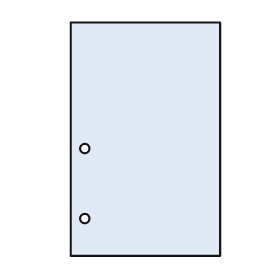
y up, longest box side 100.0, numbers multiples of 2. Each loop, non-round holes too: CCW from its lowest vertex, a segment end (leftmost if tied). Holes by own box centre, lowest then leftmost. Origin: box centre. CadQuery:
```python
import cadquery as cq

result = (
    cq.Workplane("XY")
    .moveTo(-32.0, -50.0)
    .lineTo(32.0, -50.0)
    .lineTo(32.0, 50.0)
    .lineTo(-32.0, 50.0)
    .close()
    .moveTo(-26.0, -34.0)
    .circle(2.0)
    .moveTo(-26.0, -4.0)
    .circle(2.0)
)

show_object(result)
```